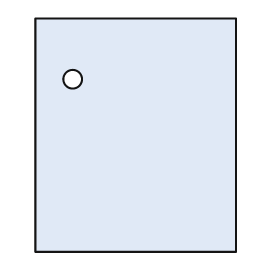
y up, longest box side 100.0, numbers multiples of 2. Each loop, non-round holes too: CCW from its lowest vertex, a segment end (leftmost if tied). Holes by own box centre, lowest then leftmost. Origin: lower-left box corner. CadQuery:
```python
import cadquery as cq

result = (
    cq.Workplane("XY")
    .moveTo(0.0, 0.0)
    .lineTo(86.0, 0.0)
    .lineTo(86.0, 100.0)
    .lineTo(0.0, 100.0)
    .close()
    .moveTo(16.0, 74.0)
    .circle(4.0)
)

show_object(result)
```